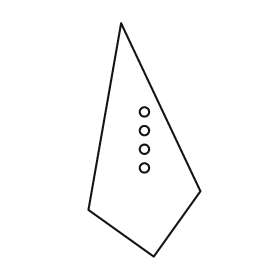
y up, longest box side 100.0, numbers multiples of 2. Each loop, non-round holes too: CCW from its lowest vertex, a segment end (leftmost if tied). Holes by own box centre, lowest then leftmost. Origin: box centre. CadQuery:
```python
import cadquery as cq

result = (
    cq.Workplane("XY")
    .moveTo(4.0, -50.0)
    .lineTo(24.0, -22.0)
    .lineTo(-10.0, 50.0)
    .lineTo(-24.0, -30.0)
    .close()
    .moveTo(0.0, -12.0)
    .circle(2.0)
    .moveTo(0.0, -4.0)
    .circle(2.0)
    .moveTo(0.0, 4.0)
    .circle(2.0)
    .moveTo(0.0, 12.0)
    .circle(2.0)
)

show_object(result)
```